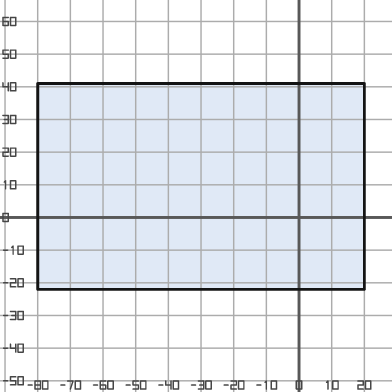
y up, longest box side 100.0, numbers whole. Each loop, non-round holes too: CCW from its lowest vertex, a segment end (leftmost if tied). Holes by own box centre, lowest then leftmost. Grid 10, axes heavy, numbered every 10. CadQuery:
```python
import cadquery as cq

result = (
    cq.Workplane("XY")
    .moveTo(-80.0, -22.0)
    .lineTo(20.0, -22.0)
    .lineTo(20.0, 41.0)
    .lineTo(-80.0, 41.0)
    .close()
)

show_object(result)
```